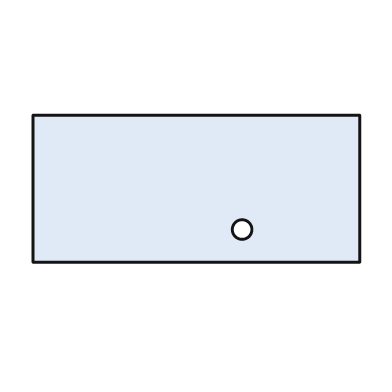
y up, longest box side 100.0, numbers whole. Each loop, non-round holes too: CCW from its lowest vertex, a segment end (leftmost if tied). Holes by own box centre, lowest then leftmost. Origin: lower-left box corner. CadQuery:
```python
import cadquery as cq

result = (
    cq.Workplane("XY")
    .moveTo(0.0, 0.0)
    .lineTo(100.0, 0.0)
    .lineTo(100.0, 45.0)
    .lineTo(0.0, 45.0)
    .close()
    .moveTo(64.0, 10.0)
    .circle(3.0)
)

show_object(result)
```